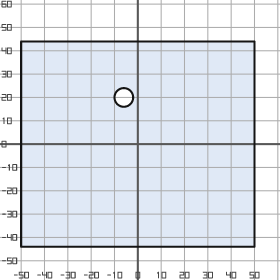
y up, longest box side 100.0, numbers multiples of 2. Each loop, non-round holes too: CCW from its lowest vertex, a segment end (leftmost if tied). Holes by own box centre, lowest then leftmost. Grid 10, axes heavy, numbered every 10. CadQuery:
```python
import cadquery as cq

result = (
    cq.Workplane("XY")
    .moveTo(-50.0, -44.0)
    .lineTo(50.0, -44.0)
    .lineTo(50.0, 44.0)
    .lineTo(-50.0, 44.0)
    .close()
    .moveTo(-6.0, 20.0)
    .circle(4.0)
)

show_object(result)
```